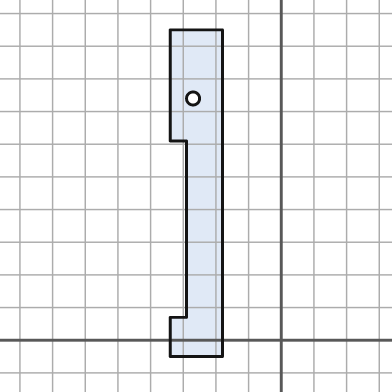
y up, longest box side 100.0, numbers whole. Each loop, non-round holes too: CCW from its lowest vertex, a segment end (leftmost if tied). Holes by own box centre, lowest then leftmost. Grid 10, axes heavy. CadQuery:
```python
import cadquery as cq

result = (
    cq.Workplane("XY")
    .moveTo(-34.0, -5.0)
    .lineTo(-18.0, -5.0)
    .lineTo(-18.0, 95.0)
    .lineTo(-34.0, 95.0)
    .lineTo(-34.0, 61.0)
    .lineTo(-29.0, 61.0)
    .lineTo(-29.0, 7.0)
    .lineTo(-34.0, 7.0)
    .close()
    .moveTo(-27.0, 74.0)
    .circle(2.0)
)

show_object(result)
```